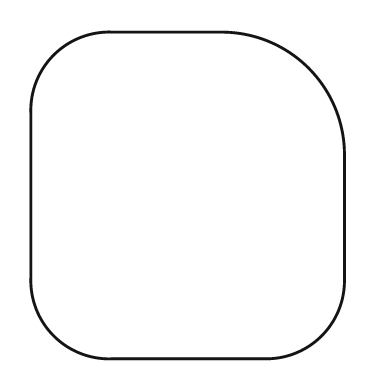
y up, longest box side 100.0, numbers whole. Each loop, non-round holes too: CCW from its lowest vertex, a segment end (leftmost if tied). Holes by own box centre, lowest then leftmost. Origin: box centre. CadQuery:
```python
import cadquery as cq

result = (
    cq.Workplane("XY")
    .moveTo(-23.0, -50.0)
    .lineTo(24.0, -50.0)
    .threePointArc((41.0, -43.0), (48.0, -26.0))
    .lineTo(48.0, 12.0)
    .threePointArc((37.0, 39.0), (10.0, 50.0))
    .lineTo(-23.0, 50.0)
    .threePointArc((-41.0, 43.0), (-48.0, 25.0))
    .lineTo(-48.0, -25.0)
    .threePointArc((-41.0, -43.0), (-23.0, -50.0))
    .close()
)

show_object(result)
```